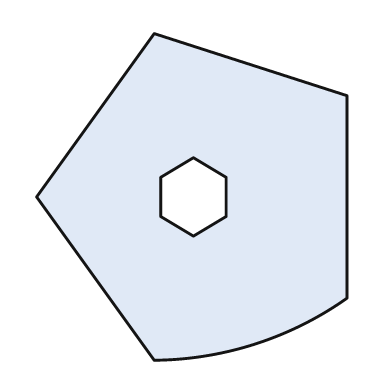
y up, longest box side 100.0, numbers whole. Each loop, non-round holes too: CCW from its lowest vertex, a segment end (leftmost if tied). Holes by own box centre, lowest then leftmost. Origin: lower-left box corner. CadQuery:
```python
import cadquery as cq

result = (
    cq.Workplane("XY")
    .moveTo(36.0, 0.0)
    .threePointArc((67.0, 5.0), (95.0, 19.0))
    .lineTo(95.0, 81.0)
    .lineTo(36.0, 100.0)
    .lineTo(0.0, 50.0)
    .close()
    .moveTo(48.0, 38.0)
    .lineTo(58.0, 44.0)
    .lineTo(58.0, 56.0)
    .lineTo(48.0, 62.0)
    .lineTo(38.0, 56.0)
    .lineTo(38.0, 44.0)
    .close()
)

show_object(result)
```